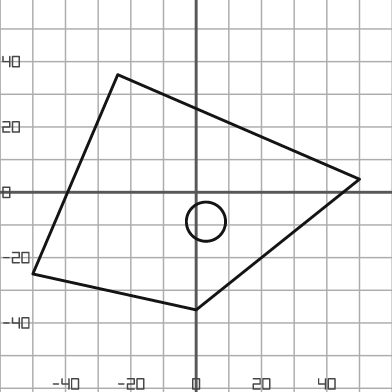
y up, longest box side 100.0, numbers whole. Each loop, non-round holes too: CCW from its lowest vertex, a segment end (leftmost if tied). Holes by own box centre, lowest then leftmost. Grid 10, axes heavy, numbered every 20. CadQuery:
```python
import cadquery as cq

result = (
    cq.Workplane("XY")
    .moveTo(0.0, -36.0)
    .lineTo(50.0, 4.0)
    .lineTo(-24.0, 36.0)
    .lineTo(-50.0, -25.0)
    .close()
    .moveTo(3.0, -9.0)
    .circle(6.0)
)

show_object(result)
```